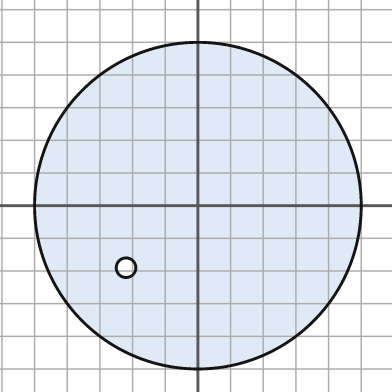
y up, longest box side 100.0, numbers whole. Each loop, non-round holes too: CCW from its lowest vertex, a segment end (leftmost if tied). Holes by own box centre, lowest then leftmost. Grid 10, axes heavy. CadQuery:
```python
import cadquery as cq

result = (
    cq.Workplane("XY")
    .moveTo(0.0, 0.0)
    .circle(50.0)
    .moveTo(-22.0, -19.0)
    .circle(3.0)
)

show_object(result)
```